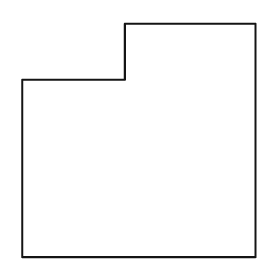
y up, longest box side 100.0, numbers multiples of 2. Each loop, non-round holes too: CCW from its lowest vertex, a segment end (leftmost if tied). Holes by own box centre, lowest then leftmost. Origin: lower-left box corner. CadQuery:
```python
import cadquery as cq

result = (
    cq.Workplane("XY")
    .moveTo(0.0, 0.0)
    .lineTo(100.0, 0.0)
    .lineTo(100.0, 100.0)
    .lineTo(44.0, 100.0)
    .lineTo(44.0, 76.0)
    .lineTo(0.0, 76.0)
    .close()
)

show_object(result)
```